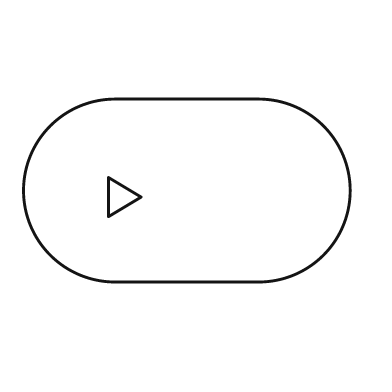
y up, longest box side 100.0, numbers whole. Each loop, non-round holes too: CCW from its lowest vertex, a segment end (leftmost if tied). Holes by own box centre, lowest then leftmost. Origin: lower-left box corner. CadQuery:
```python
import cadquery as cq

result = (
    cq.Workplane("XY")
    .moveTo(28.0, 0.0)
    .lineTo(72.0, 0.0)
    .threePointArc((100.0, 28.0), (72.0, 56.0))
    .lineTo(28.0, 56.0)
    .threePointArc((0.0, 28.0), (28.0, 0.0))
    .close()
    .moveTo(26.0, 20.0)
    .lineTo(36.0, 26.0)
    .lineTo(26.0, 32.0)
    .close()
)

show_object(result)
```